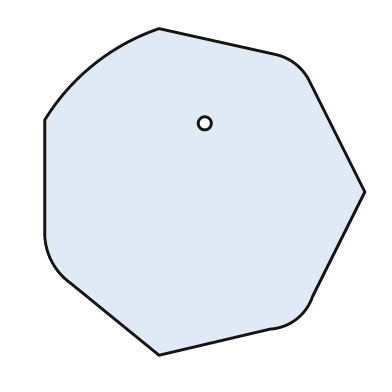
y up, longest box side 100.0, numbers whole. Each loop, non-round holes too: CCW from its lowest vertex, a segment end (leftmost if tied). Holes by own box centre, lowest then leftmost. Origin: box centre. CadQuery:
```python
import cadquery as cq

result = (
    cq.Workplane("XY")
    .moveTo(-14.0, -50.0)
    .lineTo(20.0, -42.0)
    .threePointArc((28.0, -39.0), (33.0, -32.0))
    .lineTo(49.0, 0.0)
    .lineTo(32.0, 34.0)
    .threePointArc((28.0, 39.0), (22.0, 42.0))
    .lineTo(-14.0, 50.0)
    .threePointArc((-34.0, 39.0), (-49.0, 22.0))
    .lineTo(-49.0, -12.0)
    .threePointArc((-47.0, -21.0), (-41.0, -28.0))
    .close()
    .moveTo(0.0, 21.0)
    .circle(2.0)
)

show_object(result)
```